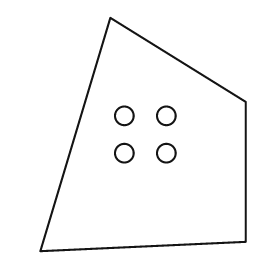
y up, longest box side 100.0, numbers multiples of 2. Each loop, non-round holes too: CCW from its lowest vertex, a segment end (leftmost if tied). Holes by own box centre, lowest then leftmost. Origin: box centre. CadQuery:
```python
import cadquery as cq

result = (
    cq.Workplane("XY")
    .moveTo(-44.0, -50.0)
    .lineTo(44.0, -46.0)
    .lineTo(44.0, 14.0)
    .lineTo(-14.0, 50.0)
    .close()
    .moveTo(-8.0, -8.0)
    .circle(4.0)
    .moveTo(10.0, -8.0)
    .circle(4.0)
    .moveTo(-8.0, 8.0)
    .circle(4.0)
    .moveTo(10.0, 8.0)
    .circle(4.0)
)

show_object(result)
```